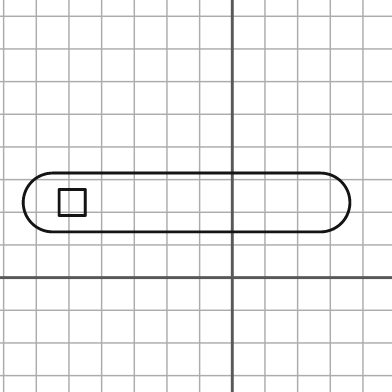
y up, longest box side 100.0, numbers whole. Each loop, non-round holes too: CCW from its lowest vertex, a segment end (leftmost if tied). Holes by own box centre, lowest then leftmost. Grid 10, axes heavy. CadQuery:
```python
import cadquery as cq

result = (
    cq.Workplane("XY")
    .moveTo(-55.0, 14.0)
    .lineTo(27.0, 14.0)
    .threePointArc((36.0, 23.0), (27.0, 32.0))
    .lineTo(-55.0, 32.0)
    .threePointArc((-64.0, 23.0), (-55.0, 14.0))
    .close()
    .moveTo(-53.0, 19.0)
    .lineTo(-45.0, 19.0)
    .lineTo(-45.0, 27.0)
    .lineTo(-53.0, 27.0)
    .close()
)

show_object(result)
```